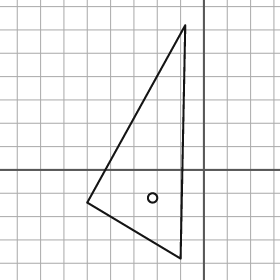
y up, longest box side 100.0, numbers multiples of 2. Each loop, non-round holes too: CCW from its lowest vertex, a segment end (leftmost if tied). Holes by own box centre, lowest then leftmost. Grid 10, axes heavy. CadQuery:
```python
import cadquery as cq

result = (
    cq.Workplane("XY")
    .moveTo(-10.0, -38.0)
    .lineTo(-8.0, 62.0)
    .lineTo(-50.0, -14.0)
    .close()
    .moveTo(-22.0, -12.0)
    .circle(2.0)
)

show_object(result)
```